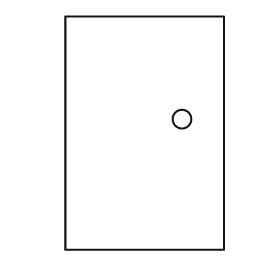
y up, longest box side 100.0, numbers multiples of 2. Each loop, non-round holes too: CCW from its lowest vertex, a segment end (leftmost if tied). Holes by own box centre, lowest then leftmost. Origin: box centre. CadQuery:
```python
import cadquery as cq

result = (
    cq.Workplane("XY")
    .moveTo(-34.0, -50.0)
    .lineTo(34.0, -50.0)
    .lineTo(34.0, 50.0)
    .lineTo(-34.0, 50.0)
    .close()
    .moveTo(16.0, 6.0)
    .circle(4.0)
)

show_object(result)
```